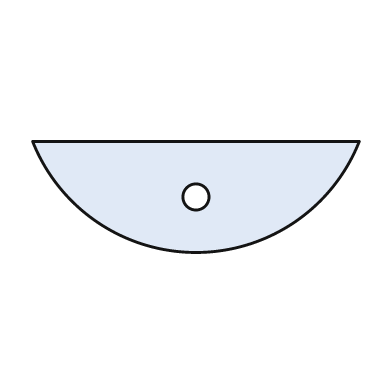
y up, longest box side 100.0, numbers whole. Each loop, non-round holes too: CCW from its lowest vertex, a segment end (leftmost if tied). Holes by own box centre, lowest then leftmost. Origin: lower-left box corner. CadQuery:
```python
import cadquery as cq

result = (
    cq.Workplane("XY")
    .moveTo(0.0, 34.0)
    .threePointArc((50.0, 0.0), (100.0, 34.0))
    .close()
    .moveTo(50.0, 17.0)
    .circle(4.0)
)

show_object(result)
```